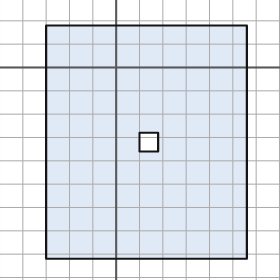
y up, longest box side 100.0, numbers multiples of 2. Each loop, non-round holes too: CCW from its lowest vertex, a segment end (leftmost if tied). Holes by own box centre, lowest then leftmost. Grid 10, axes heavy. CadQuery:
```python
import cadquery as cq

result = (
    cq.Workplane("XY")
    .moveTo(-30.0, -82.0)
    .lineTo(56.0, -82.0)
    .lineTo(56.0, 18.0)
    .lineTo(-30.0, 18.0)
    .close()
    .moveTo(10.0, -36.0)
    .lineTo(18.0, -36.0)
    .lineTo(18.0, -28.0)
    .lineTo(10.0, -28.0)
    .close()
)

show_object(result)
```